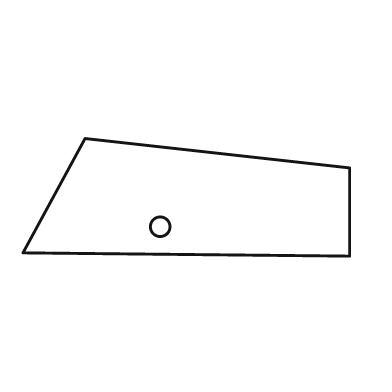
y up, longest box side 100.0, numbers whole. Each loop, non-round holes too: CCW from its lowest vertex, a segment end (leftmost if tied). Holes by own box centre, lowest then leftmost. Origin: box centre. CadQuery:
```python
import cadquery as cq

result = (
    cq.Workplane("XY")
    .moveTo(50.0, -18.0)
    .lineTo(50.0, 9.0)
    .lineTo(-31.0, 18.0)
    .lineTo(-50.0, -17.0)
    .close()
    .moveTo(-8.0, -9.0)
    .circle(3.0)
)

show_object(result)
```